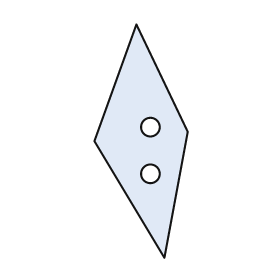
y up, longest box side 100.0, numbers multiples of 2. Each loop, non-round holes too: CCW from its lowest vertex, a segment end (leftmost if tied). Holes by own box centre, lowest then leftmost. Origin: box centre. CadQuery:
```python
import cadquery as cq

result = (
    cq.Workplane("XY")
    .moveTo(10.0, -50.0)
    .lineTo(20.0, 4.0)
    .lineTo(-2.0, 50.0)
    .lineTo(-20.0, 0.0)
    .close()
    .moveTo(4.0, -14.0)
    .circle(4.0)
    .moveTo(4.0, 6.0)
    .circle(4.0)
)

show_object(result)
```